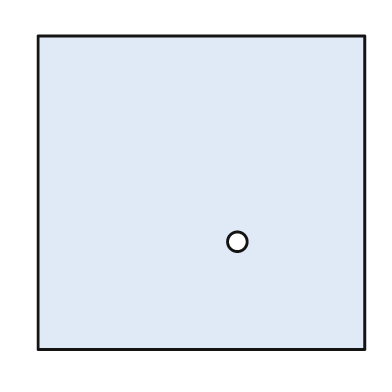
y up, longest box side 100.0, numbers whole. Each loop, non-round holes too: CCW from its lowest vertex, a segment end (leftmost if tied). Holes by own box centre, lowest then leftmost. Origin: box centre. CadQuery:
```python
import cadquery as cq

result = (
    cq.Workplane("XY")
    .moveTo(-50.0, -48.0)
    .lineTo(50.0, -48.0)
    .lineTo(50.0, 48.0)
    .lineTo(-50.0, 48.0)
    .close()
    .moveTo(11.0, -15.0)
    .circle(3.0)
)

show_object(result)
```